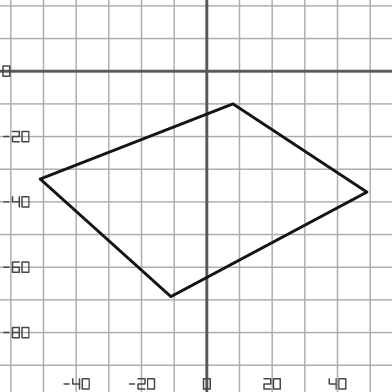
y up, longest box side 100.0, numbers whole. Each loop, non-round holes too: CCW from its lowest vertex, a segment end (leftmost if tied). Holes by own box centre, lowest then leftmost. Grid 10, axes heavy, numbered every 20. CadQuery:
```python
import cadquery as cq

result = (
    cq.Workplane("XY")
    .moveTo(-11.0, -69.0)
    .lineTo(49.0, -37.0)
    .lineTo(8.0, -10.0)
    .lineTo(-51.0, -33.0)
    .close()
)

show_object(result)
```